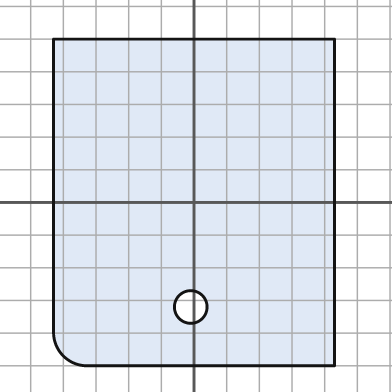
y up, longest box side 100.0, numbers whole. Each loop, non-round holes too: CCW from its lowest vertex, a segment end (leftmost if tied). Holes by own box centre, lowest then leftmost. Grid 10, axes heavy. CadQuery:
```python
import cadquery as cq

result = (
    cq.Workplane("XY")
    .moveTo(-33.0, -50.0)
    .lineTo(43.0, -50.0)
    .lineTo(43.0, 50.0)
    .lineTo(-43.0, 50.0)
    .lineTo(-43.0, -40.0)
    .threePointArc((-40.0, -47.0), (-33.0, -50.0))
    .close()
    .moveTo(-1.0, -32.0)
    .circle(5.0)
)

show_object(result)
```